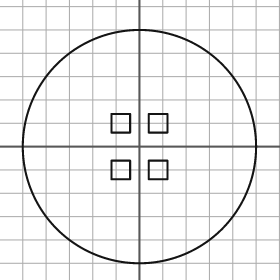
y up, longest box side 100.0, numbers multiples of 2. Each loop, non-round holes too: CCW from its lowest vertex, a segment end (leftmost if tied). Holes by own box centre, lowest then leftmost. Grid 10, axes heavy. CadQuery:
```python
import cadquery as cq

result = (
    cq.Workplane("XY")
    .moveTo(0.0, 0.0)
    .circle(50.0)
    .moveTo(-12.0, -14.0)
    .lineTo(-4.0, -14.0)
    .lineTo(-4.0, -6.0)
    .lineTo(-12.0, -6.0)
    .close()
    .moveTo(4.0, -14.0)
    .lineTo(12.0, -14.0)
    .lineTo(12.0, -6.0)
    .lineTo(4.0, -6.0)
    .close()
    .moveTo(-12.0, 6.0)
    .lineTo(-4.0, 6.0)
    .lineTo(-4.0, 14.0)
    .lineTo(-12.0, 14.0)
    .close()
    .moveTo(4.0, 6.0)
    .lineTo(12.0, 6.0)
    .lineTo(12.0, 14.0)
    .lineTo(4.0, 14.0)
    .close()
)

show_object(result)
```